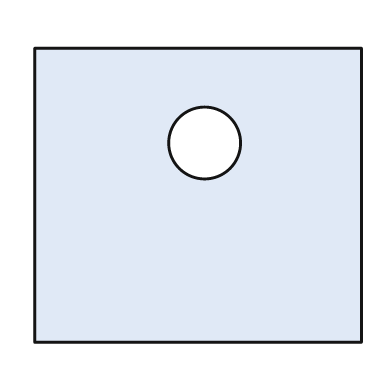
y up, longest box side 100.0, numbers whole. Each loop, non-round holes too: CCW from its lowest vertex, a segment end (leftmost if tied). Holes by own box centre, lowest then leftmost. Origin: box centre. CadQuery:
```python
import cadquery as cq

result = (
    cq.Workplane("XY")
    .moveTo(-50.0, -45.0)
    .lineTo(50.0, -45.0)
    .lineTo(50.0, 45.0)
    .lineTo(-50.0, 45.0)
    .close()
    .moveTo(2.0, 16.0)
    .circle(11.0)
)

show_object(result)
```